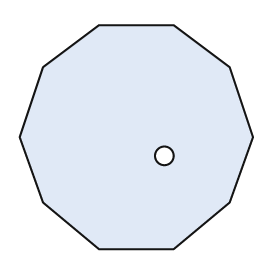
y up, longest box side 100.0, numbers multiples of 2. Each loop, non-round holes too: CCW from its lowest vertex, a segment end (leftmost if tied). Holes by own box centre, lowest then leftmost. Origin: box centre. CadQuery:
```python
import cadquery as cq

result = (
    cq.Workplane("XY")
    .moveTo(-16.0, -48.0)
    .lineTo(16.0, -48.0)
    .lineTo(40.0, -28.0)
    .lineTo(50.0, 0.0)
    .lineTo(40.0, 30.0)
    .lineTo(16.0, 48.0)
    .lineTo(-16.0, 48.0)
    .lineTo(-40.0, 30.0)
    .lineTo(-50.0, 0.0)
    .lineTo(-40.0, -28.0)
    .close()
    .moveTo(12.0, -8.0)
    .circle(4.0)
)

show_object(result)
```